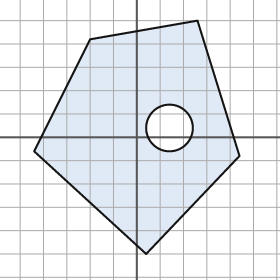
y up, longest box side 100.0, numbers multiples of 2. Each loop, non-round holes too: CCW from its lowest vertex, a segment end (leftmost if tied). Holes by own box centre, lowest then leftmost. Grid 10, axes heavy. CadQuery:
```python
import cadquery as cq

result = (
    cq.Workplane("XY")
    .moveTo(4.0, -50.0)
    .lineTo(44.0, -8.0)
    .lineTo(26.0, 50.0)
    .lineTo(-20.0, 42.0)
    .lineTo(-44.0, -6.0)
    .close()
    .moveTo(14.0, 4.0)
    .circle(10.0)
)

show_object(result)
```